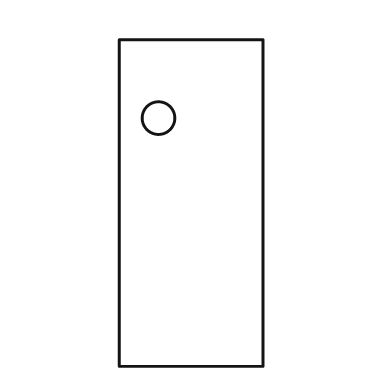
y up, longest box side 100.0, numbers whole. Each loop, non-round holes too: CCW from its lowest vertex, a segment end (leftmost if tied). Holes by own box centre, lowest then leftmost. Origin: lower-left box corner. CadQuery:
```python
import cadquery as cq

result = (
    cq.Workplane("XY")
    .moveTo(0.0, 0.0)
    .lineTo(44.0, 0.0)
    .lineTo(44.0, 100.0)
    .lineTo(0.0, 100.0)
    .close()
    .moveTo(12.0, 76.0)
    .circle(5.0)
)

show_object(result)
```